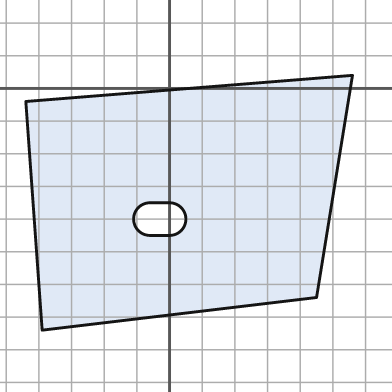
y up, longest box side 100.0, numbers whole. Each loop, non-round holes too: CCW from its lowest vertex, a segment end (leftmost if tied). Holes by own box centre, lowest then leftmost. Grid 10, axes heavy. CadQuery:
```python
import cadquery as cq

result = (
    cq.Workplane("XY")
    .moveTo(-39.0, -74.0)
    .lineTo(45.0, -64.0)
    .lineTo(56.0, 4.0)
    .lineTo(-44.0, -4.0)
    .close()
    .moveTo(-6.0, -45.0)
    .lineTo(0.0, -45.0)
    .threePointArc((5.0, -40.0), (0.0, -35.0))
    .lineTo(-6.0, -35.0)
    .threePointArc((-11.0, -40.0), (-6.0, -45.0))
    .close()
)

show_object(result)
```